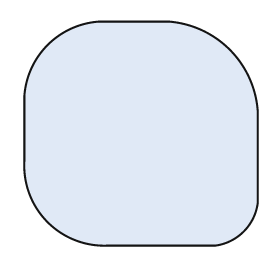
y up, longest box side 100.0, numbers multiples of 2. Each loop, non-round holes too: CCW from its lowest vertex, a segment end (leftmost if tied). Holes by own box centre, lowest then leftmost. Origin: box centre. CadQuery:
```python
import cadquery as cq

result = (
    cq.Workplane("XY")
    .moveTo(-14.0, -48.0)
    .lineTo(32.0, -48.0)
    .threePointArc((44.0, -42.0), (50.0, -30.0))
    .lineTo(50.0, 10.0)
    .threePointArc((38.0, 36.0), (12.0, 48.0))
    .lineTo(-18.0, 48.0)
    .threePointArc((-40.0, 38.0), (-50.0, 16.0))
    .lineTo(-50.0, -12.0)
    .threePointArc((-40.0, -38.0), (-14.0, -48.0))
    .close()
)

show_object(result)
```